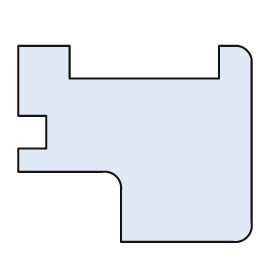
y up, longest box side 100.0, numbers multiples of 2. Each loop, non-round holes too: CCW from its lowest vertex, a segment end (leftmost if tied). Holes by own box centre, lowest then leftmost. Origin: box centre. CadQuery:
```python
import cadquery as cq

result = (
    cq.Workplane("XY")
    .moveTo(-6.0, -42.0)
    .lineTo(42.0, -42.0)
    .threePointArc((48.0, -40.0), (50.0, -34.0))
    .lineTo(50.0, 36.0)
    .threePointArc((48.0, 40.0), (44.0, 42.0))
    .lineTo(36.0, 42.0)
    .lineTo(36.0, 28.0)
    .lineTo(-28.0, 28.0)
    .lineTo(-28.0, 42.0)
    .lineTo(-50.0, 42.0)
    .lineTo(-50.0, 12.0)
    .lineTo(-38.0, 12.0)
    .lineTo(-38.0, -2.0)
    .lineTo(-50.0, -2.0)
    .lineTo(-50.0, -12.0)
    .lineTo(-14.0, -12.0)
    .threePointArc((-8.0, -14.0), (-6.0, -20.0))
    .close()
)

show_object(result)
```